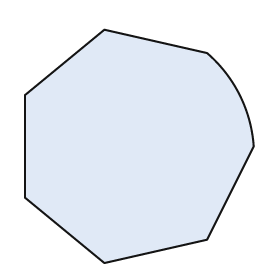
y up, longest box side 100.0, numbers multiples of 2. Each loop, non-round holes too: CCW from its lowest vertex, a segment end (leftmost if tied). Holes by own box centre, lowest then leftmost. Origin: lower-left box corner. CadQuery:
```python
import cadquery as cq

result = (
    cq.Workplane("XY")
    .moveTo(34.0, 0.0)
    .lineTo(78.0, 10.0)
    .lineTo(98.0, 50.0)
    .threePointArc((92.0, 72.0), (78.0, 90.0))
    .lineTo(34.0, 100.0)
    .lineTo(0.0, 72.0)
    .lineTo(0.0, 28.0)
    .close()
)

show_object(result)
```